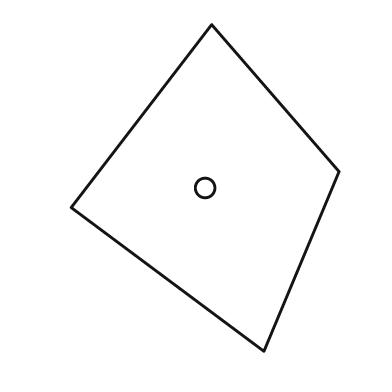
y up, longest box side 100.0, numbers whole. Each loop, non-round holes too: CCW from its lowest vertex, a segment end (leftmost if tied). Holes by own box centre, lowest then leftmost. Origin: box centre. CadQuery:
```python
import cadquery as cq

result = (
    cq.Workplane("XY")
    .moveTo(18.0, -50.0)
    .lineTo(41.0, 5.0)
    .lineTo(2.0, 50.0)
    .lineTo(-41.0, -6.0)
    .close()
    .moveTo(0.0, 0.0)
    .circle(3.0)
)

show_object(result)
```